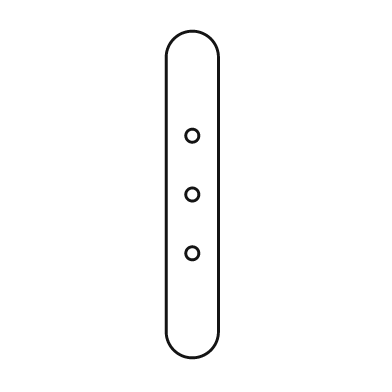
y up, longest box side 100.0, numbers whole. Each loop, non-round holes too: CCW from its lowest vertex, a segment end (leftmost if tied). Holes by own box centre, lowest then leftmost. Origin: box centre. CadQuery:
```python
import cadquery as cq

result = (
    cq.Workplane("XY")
    .moveTo(-8.0, -42.0)
    .threePointArc((0.0, -50.0), (8.0, -42.0))
    .lineTo(8.0, 42.0)
    .threePointArc((0.0, 50.0), (-8.0, 42.0))
    .close()
    .moveTo(0.0, -18.0)
    .circle(2.0)
    .moveTo(0.0, 0.0)
    .circle(2.0)
    .moveTo(0.0, 18.0)
    .circle(2.0)
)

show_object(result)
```